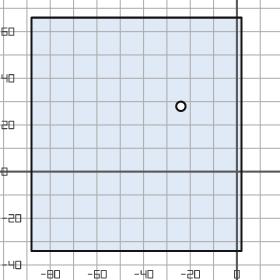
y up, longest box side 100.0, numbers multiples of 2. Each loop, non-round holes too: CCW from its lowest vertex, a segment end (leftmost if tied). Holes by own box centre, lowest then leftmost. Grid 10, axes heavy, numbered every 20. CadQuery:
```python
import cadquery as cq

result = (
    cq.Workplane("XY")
    .moveTo(-88.0, -34.0)
    .lineTo(2.0, -34.0)
    .lineTo(2.0, 66.0)
    .lineTo(-88.0, 66.0)
    .close()
    .moveTo(-24.0, 28.0)
    .circle(2.0)
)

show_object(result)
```